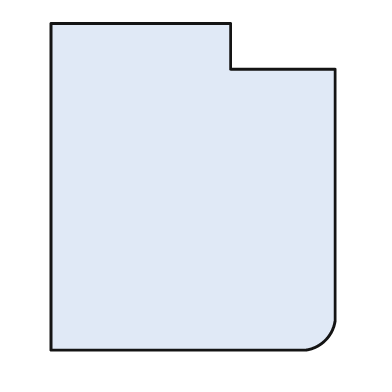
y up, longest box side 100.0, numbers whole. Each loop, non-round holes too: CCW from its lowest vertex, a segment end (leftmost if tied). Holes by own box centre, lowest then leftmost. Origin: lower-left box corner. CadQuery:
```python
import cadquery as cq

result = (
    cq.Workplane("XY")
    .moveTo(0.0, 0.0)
    .lineTo(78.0, 0.0)
    .threePointArc((84.0, 3.0), (87.0, 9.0))
    .lineTo(87.0, 86.0)
    .lineTo(55.0, 86.0)
    .lineTo(55.0, 100.0)
    .lineTo(0.0, 100.0)
    .close()
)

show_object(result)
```